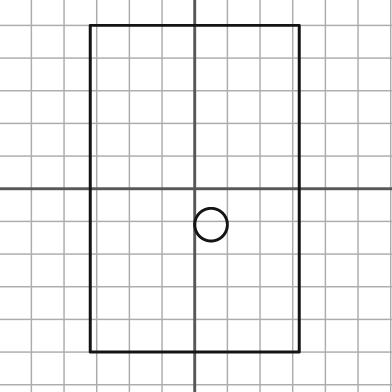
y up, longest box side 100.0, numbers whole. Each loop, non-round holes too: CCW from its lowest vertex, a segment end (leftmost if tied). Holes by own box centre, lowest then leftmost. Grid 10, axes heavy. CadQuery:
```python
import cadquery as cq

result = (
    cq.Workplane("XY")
    .moveTo(-32.0, -50.0)
    .lineTo(32.0, -50.0)
    .lineTo(32.0, 50.0)
    .lineTo(-32.0, 50.0)
    .close()
    .moveTo(5.0, -11.0)
    .circle(5.0)
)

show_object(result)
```